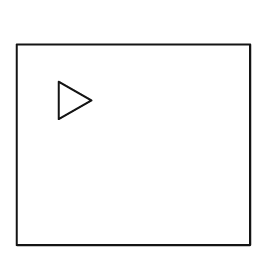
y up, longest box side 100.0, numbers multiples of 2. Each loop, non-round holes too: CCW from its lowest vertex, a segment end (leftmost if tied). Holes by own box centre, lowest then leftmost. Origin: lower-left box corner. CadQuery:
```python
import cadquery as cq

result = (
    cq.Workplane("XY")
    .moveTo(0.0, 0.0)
    .lineTo(100.0, 0.0)
    .lineTo(100.0, 86.0)
    .lineTo(0.0, 86.0)
    .close()
    .moveTo(18.0, 54.0)
    .lineTo(32.0, 62.0)
    .lineTo(18.0, 70.0)
    .close()
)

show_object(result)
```